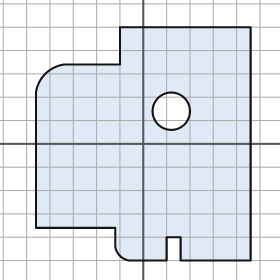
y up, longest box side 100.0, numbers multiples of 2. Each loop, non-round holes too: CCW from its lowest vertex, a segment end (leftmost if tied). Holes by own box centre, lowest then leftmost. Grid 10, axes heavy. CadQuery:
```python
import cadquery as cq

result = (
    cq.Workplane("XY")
    .moveTo(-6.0, -50.0)
    .lineTo(10.0, -50.0)
    .lineTo(10.0, -40.0)
    .lineTo(16.0, -40.0)
    .lineTo(16.0, -50.0)
    .lineTo(46.0, -50.0)
    .lineTo(46.0, 50.0)
    .lineTo(-10.0, 50.0)
    .lineTo(-10.0, 34.0)
    .lineTo(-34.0, 34.0)
    .threePointArc((-42.0, 30.0), (-46.0, 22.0))
    .lineTo(-46.0, -36.0)
    .lineTo(-12.0, -36.0)
    .lineTo(-12.0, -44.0)
    .threePointArc((-10.0, -48.0), (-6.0, -50.0))
    .close()
    .moveTo(12.0, 14.0)
    .circle(8.0)
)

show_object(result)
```